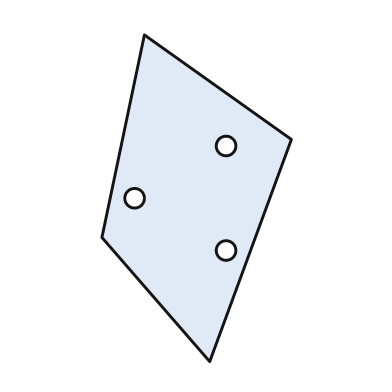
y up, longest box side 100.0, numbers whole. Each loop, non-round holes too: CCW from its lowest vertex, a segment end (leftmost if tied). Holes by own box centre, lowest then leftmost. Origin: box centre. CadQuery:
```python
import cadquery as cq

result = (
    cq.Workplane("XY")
    .moveTo(4.0, -50.0)
    .lineTo(29.0, 18.0)
    .lineTo(-16.0, 50.0)
    .lineTo(-29.0, -12.0)
    .close()
    .moveTo(9.0, -16.0)
    .circle(3.0)
    .moveTo(-19.0, 0.0)
    .circle(3.0)
    .moveTo(9.0, 16.0)
    .circle(3.0)
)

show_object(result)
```